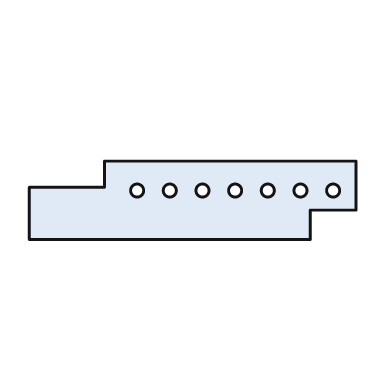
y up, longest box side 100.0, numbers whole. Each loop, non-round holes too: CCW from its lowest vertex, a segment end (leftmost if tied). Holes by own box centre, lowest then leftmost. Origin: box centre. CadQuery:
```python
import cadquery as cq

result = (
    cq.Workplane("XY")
    .moveTo(-50.0, -12.0)
    .lineTo(36.0, -12.0)
    .lineTo(36.0, -3.0)
    .lineTo(50.0, -3.0)
    .lineTo(50.0, 12.0)
    .lineTo(-27.0, 12.0)
    .lineTo(-27.0, 4.0)
    .lineTo(-50.0, 4.0)
    .close()
    .moveTo(-17.0, 3.0)
    .circle(2.0)
    .moveTo(-7.0, 3.0)
    .circle(2.0)
    .moveTo(3.0, 3.0)
    .circle(2.0)
    .moveTo(13.0, 3.0)
    .circle(2.0)
    .moveTo(23.0, 3.0)
    .circle(2.0)
    .moveTo(33.0, 3.0)
    .circle(2.0)
    .moveTo(43.0, 3.0)
    .circle(2.0)
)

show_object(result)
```